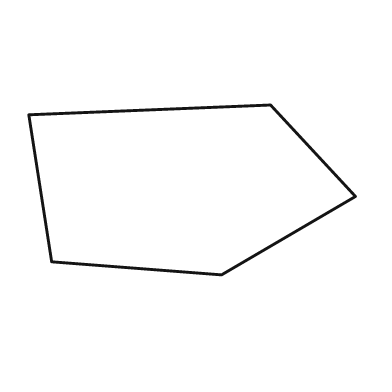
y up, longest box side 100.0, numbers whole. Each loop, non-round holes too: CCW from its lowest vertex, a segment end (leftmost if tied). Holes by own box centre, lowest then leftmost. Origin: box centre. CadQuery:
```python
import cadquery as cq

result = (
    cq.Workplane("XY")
    .moveTo(9.0, -26.0)
    .lineTo(50.0, -2.0)
    .lineTo(24.0, 26.0)
    .lineTo(-50.0, 23.0)
    .lineTo(-43.0, -22.0)
    .close()
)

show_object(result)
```